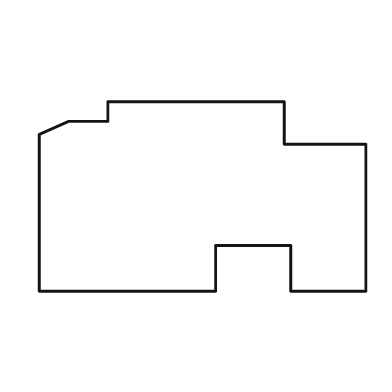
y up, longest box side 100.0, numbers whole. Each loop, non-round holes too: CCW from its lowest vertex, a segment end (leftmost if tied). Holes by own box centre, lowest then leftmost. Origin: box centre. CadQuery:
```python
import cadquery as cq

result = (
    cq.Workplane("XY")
    .moveTo(-50.0, -29.0)
    .lineTo(4.0, -29.0)
    .lineTo(4.0, -15.0)
    .lineTo(27.0, -15.0)
    .lineTo(27.0, -29.0)
    .lineTo(50.0, -29.0)
    .lineTo(50.0, 16.0)
    .lineTo(25.0, 16.0)
    .lineTo(25.0, 29.0)
    .lineTo(-29.0, 29.0)
    .lineTo(-29.0, 23.0)
    .lineTo(-41.0, 23.0)
    .lineTo(-50.0, 19.0)
    .close()
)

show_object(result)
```